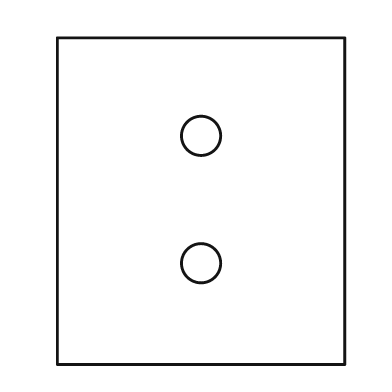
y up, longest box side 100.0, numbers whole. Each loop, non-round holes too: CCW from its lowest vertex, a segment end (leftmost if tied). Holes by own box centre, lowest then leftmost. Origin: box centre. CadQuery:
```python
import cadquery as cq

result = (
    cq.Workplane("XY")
    .moveTo(-44.0, -50.0)
    .lineTo(44.0, -50.0)
    .lineTo(44.0, 50.0)
    .lineTo(-44.0, 50.0)
    .close()
    .moveTo(0.0, -19.0)
    .circle(6.0)
    .moveTo(0.0, 20.0)
    .circle(6.0)
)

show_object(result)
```